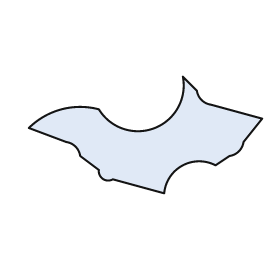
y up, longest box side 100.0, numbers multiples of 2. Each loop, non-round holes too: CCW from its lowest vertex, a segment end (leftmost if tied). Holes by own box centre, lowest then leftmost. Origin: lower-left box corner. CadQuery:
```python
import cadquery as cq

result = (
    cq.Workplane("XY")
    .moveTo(58.0, 0.0)
    .threePointArc((66.0, 12.0), (80.0, 12.0))
    .lineTo(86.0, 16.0)
    .threePointArc((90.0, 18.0), (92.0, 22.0))
    .lineTo(100.0, 32.0)
    .lineTo(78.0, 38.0)
    .threePointArc((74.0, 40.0), (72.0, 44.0))
    .lineTo(66.0, 50.0)
    .threePointArc((54.0, 28.0), (30.0, 36.0))
    .threePointArc((14.0, 36.0), (0.0, 28.0))
    .lineTo(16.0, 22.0)
    .threePointArc((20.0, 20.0), (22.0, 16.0))
    .lineTo(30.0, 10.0)
    .threePointArc((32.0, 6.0), (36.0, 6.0))
    .close()
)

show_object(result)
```